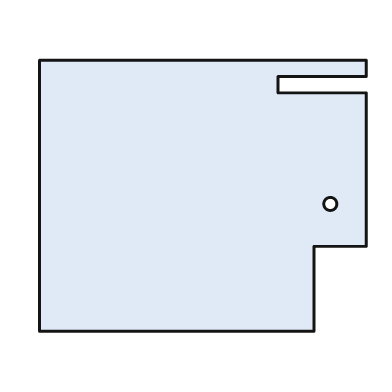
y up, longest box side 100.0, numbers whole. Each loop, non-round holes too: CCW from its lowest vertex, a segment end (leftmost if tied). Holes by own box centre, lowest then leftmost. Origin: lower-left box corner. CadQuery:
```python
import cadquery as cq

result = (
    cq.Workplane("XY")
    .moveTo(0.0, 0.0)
    .lineTo(84.0, 0.0)
    .lineTo(84.0, 26.0)
    .lineTo(100.0, 26.0)
    .lineTo(100.0, 73.0)
    .lineTo(73.0, 73.0)
    .lineTo(73.0, 78.0)
    .lineTo(100.0, 78.0)
    .lineTo(100.0, 83.0)
    .lineTo(0.0, 83.0)
    .close()
    .moveTo(89.0, 39.0)
    .circle(2.0)
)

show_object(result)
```